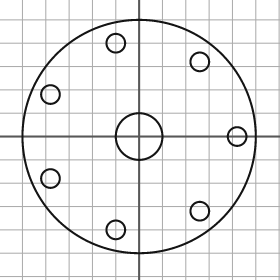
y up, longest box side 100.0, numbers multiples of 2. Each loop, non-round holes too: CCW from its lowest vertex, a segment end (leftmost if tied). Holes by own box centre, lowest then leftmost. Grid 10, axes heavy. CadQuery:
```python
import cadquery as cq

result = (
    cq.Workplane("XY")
    .moveTo(0.0, 0.0)
    .circle(50.0)
    .moveTo(-10.0, -40.0)
    .circle(4.0)
    .moveTo(26.0, -32.0)
    .circle(4.0)
    .moveTo(-38.0, -18.0)
    .circle(4.0)
    .moveTo(0.0, 0.0)
    .circle(10.0)
    .moveTo(42.0, 0.0)
    .circle(4.0)
    .moveTo(-38.0, 18.0)
    .circle(4.0)
    .moveTo(26.0, 32.0)
    .circle(4.0)
    .moveTo(-10.0, 40.0)
    .circle(4.0)
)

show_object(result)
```